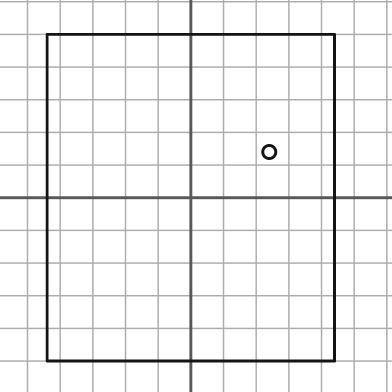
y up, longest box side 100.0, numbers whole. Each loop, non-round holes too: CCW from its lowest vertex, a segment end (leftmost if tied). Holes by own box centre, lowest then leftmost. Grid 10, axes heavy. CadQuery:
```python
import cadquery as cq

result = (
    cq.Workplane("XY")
    .moveTo(-44.0, -50.0)
    .lineTo(44.0, -50.0)
    .lineTo(44.0, 50.0)
    .lineTo(-44.0, 50.0)
    .close()
    .moveTo(24.0, 14.0)
    .circle(2.0)
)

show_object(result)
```